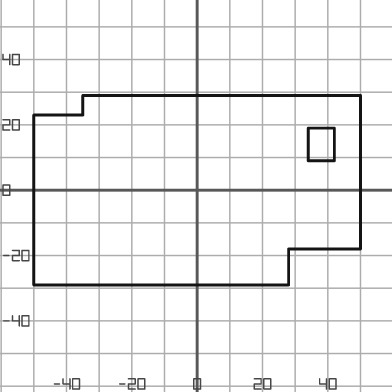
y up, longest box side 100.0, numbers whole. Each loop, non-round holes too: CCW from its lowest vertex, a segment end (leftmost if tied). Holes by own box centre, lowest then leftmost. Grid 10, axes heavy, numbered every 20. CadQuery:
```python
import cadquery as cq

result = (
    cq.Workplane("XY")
    .moveTo(-50.0, -29.0)
    .lineTo(28.0, -29.0)
    .lineTo(28.0, -18.0)
    .lineTo(50.0, -18.0)
    .lineTo(50.0, 29.0)
    .lineTo(-35.0, 29.0)
    .lineTo(-35.0, 23.0)
    .lineTo(-50.0, 23.0)
    .close()
    .moveTo(34.0, 9.0)
    .lineTo(42.0, 9.0)
    .lineTo(42.0, 19.0)
    .lineTo(34.0, 19.0)
    .close()
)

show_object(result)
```